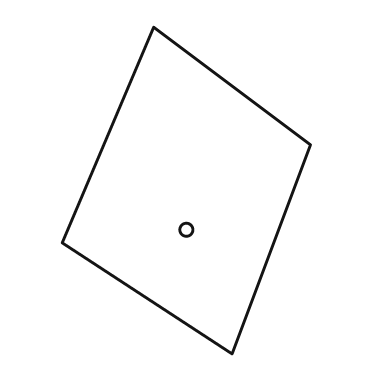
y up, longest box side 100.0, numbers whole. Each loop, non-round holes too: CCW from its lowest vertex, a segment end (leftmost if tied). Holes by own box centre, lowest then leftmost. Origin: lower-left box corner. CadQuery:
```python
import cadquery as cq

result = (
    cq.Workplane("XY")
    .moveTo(52.0, 0.0)
    .lineTo(76.0, 64.0)
    .lineTo(28.0, 100.0)
    .lineTo(0.0, 34.0)
    .close()
    .moveTo(38.0, 38.0)
    .circle(2.0)
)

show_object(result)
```